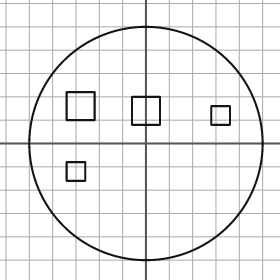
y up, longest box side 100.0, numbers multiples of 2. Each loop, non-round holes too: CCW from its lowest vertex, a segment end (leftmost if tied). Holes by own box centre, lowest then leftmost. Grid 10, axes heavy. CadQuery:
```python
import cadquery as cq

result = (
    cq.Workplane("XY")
    .moveTo(0.0, 0.0)
    .circle(50.0)
    .moveTo(-34.0, -16.0)
    .lineTo(-26.0, -16.0)
    .lineTo(-26.0, -8.0)
    .lineTo(-34.0, -8.0)
    .close()
    .moveTo(28.0, 8.0)
    .lineTo(36.0, 8.0)
    .lineTo(36.0, 16.0)
    .lineTo(28.0, 16.0)
    .close()
    .moveTo(-6.0, 8.0)
    .lineTo(6.0, 8.0)
    .lineTo(6.0, 20.0)
    .lineTo(-6.0, 20.0)
    .close()
    .moveTo(-34.0, 10.0)
    .lineTo(-22.0, 10.0)
    .lineTo(-22.0, 22.0)
    .lineTo(-34.0, 22.0)
    .close()
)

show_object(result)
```